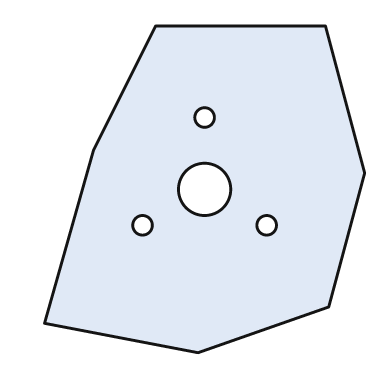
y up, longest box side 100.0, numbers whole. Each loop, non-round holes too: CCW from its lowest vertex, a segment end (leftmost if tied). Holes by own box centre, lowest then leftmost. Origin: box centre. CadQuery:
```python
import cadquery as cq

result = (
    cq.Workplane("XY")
    .moveTo(-2.0, -50.0)
    .lineTo(38.0, -36.0)
    .lineTo(49.0, 5.0)
    .lineTo(37.0, 50.0)
    .lineTo(-15.0, 50.0)
    .lineTo(-34.0, 12.0)
    .lineTo(-49.0, -41.0)
    .close()
    .moveTo(-19.0, -11.0)
    .circle(3.0)
    .moveTo(19.0, -11.0)
    .circle(3.0)
    .moveTo(0.0, 0.0)
    .circle(8.0)
    .moveTo(0.0, 22.0)
    .circle(3.0)
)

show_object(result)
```